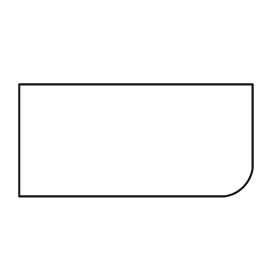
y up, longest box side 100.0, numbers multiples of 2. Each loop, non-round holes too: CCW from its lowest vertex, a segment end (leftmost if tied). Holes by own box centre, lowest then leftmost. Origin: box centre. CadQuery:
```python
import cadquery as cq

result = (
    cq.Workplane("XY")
    .moveTo(-50.0, -24.0)
    .lineTo(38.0, -24.0)
    .threePointArc((46.0, -20.0), (50.0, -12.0))
    .lineTo(50.0, 24.0)
    .lineTo(-50.0, 24.0)
    .close()
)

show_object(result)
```